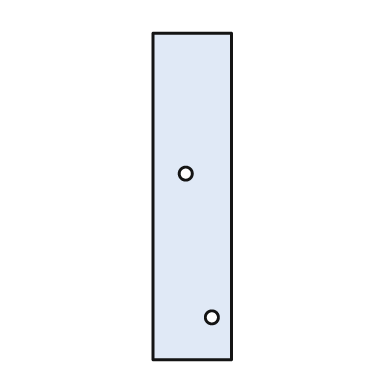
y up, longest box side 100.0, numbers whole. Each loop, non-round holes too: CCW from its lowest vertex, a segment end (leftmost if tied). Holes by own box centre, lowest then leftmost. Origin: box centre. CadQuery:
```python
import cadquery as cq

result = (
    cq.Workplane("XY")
    .moveTo(-12.0, -50.0)
    .lineTo(12.0, -50.0)
    .lineTo(12.0, 50.0)
    .lineTo(-12.0, 50.0)
    .close()
    .moveTo(6.0, -37.0)
    .circle(2.0)
    .moveTo(-2.0, 7.0)
    .circle(2.0)
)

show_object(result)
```